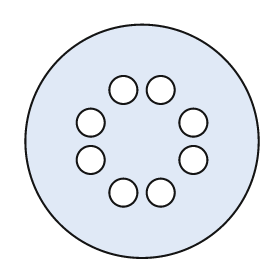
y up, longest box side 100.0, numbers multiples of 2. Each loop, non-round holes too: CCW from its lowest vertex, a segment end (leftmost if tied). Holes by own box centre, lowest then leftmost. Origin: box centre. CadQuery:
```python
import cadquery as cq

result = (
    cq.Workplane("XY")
    .moveTo(0.0, 0.0)
    .circle(50.0)
    .moveTo(-8.0, -22.0)
    .circle(6.0)
    .moveTo(8.0, -22.0)
    .circle(6.0)
    .moveTo(-22.0, -8.0)
    .circle(6.0)
    .moveTo(22.0, -8.0)
    .circle(6.0)
    .moveTo(-22.0, 8.0)
    .circle(6.0)
    .moveTo(22.0, 8.0)
    .circle(6.0)
    .moveTo(-8.0, 22.0)
    .circle(6.0)
    .moveTo(8.0, 22.0)
    .circle(6.0)
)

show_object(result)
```